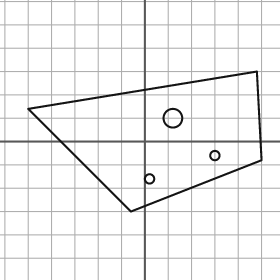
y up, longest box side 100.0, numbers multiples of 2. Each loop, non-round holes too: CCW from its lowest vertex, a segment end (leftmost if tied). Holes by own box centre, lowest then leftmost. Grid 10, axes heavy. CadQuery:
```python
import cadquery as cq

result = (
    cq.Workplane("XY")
    .moveTo(-6.0, -30.0)
    .lineTo(50.0, -8.0)
    .lineTo(48.0, 30.0)
    .lineTo(-50.0, 14.0)
    .close()
    .moveTo(2.0, -16.0)
    .circle(2.0)
    .moveTo(30.0, -6.0)
    .circle(2.0)
    .moveTo(12.0, 10.0)
    .circle(4.0)
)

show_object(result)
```